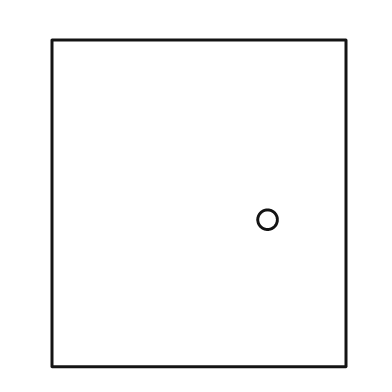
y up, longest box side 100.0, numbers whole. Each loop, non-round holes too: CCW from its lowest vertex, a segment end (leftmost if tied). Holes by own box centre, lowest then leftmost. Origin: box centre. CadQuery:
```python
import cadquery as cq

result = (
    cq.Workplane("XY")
    .moveTo(-45.0, -50.0)
    .lineTo(45.0, -50.0)
    .lineTo(45.0, 50.0)
    .lineTo(-45.0, 50.0)
    .close()
    .moveTo(21.0, -5.0)
    .circle(3.0)
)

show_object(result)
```